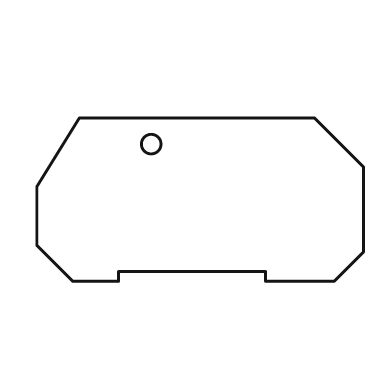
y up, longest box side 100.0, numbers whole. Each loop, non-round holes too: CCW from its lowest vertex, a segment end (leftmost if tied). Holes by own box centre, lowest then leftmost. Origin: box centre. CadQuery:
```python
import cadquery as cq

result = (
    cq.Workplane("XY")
    .moveTo(-39.0, -25.0)
    .lineTo(-25.0, -25.0)
    .lineTo(-25.0, -22.0)
    .lineTo(20.0, -22.0)
    .lineTo(20.0, -25.0)
    .lineTo(41.0, -25.0)
    .lineTo(50.0, -16.0)
    .lineTo(50.0, 10.0)
    .lineTo(35.0, 25.0)
    .lineTo(-37.0, 25.0)
    .lineTo(-50.0, 4.0)
    .lineTo(-50.0, -14.0)
    .close()
    .moveTo(-15.0, 17.0)
    .circle(3.0)
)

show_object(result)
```